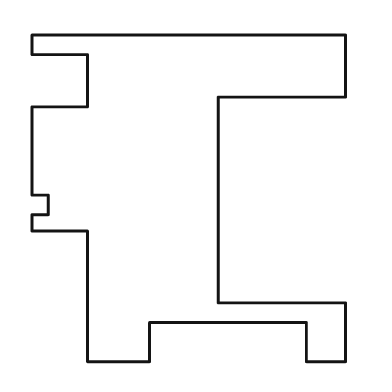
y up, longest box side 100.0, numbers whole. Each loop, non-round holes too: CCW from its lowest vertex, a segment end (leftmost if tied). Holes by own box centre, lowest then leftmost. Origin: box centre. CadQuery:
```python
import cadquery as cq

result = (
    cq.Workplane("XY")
    .moveTo(-31.0, -50.0)
    .lineTo(-12.0, -50.0)
    .lineTo(-12.0, -38.0)
    .lineTo(36.0, -38.0)
    .lineTo(36.0, -50.0)
    .lineTo(48.0, -50.0)
    .lineTo(48.0, -32.0)
    .lineTo(9.0, -32.0)
    .lineTo(9.0, 31.0)
    .lineTo(48.0, 31.0)
    .lineTo(48.0, 50.0)
    .lineTo(-48.0, 50.0)
    .lineTo(-48.0, 44.0)
    .lineTo(-31.0, 44.0)
    .lineTo(-31.0, 28.0)
    .lineTo(-48.0, 28.0)
    .lineTo(-48.0, 1.0)
    .lineTo(-43.0, 1.0)
    .lineTo(-43.0, -5.0)
    .lineTo(-48.0, -5.0)
    .lineTo(-48.0, -10.0)
    .lineTo(-31.0, -10.0)
    .close()
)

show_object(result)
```